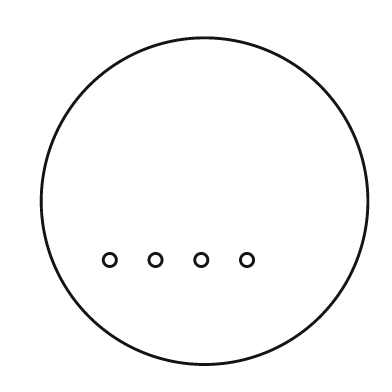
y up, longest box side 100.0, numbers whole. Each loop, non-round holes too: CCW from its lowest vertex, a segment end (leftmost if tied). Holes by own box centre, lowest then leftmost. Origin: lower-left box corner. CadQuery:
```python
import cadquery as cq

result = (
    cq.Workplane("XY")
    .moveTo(50.0, 50.0)
    .circle(50.0)
    .moveTo(21.0, 32.0)
    .circle(2.0)
    .moveTo(35.0, 32.0)
    .circle(2.0)
    .moveTo(49.0, 32.0)
    .circle(2.0)
    .moveTo(63.0, 32.0)
    .circle(2.0)
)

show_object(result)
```